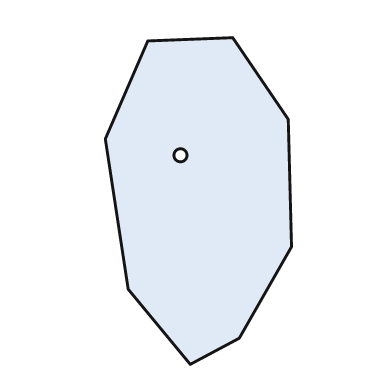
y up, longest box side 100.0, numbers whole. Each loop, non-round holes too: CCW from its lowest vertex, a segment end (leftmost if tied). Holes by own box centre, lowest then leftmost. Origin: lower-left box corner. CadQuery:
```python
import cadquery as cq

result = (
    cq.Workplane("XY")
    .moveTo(26.0, 0.0)
    .lineTo(41.0, 8.0)
    .lineTo(57.0, 36.0)
    .lineTo(56.0, 75.0)
    .lineTo(39.0, 100.0)
    .lineTo(13.0, 99.0)
    .lineTo(0.0, 69.0)
    .lineTo(7.0, 23.0)
    .close()
    .moveTo(23.0, 64.0)
    .circle(2.0)
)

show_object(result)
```